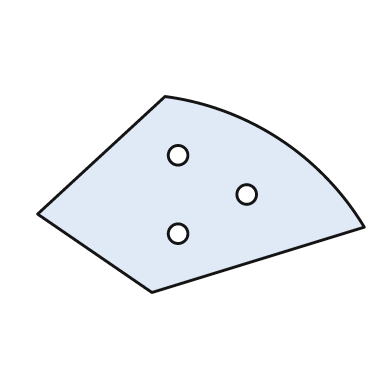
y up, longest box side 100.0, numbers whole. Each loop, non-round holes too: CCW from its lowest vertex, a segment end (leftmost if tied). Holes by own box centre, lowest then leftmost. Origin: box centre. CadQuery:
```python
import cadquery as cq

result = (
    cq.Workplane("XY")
    .moveTo(-15.0, -30.0)
    .lineTo(50.0, -10.0)
    .threePointArc((24.0, 17.0), (-11.0, 30.0))
    .lineTo(-50.0, -6.0)
    .close()
    .moveTo(-7.0, -12.0)
    .circle(3.0)
    .moveTo(14.0, 0.0)
    .circle(3.0)
    .moveTo(-7.0, 12.0)
    .circle(3.0)
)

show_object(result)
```